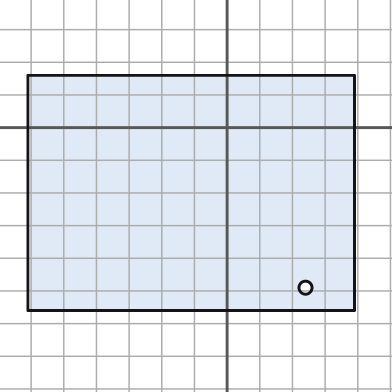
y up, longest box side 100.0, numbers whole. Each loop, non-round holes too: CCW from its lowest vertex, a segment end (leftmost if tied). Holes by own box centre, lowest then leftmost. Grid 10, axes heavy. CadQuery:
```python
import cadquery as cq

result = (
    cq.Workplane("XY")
    .moveTo(-61.0, -56.0)
    .lineTo(39.0, -56.0)
    .lineTo(39.0, 16.0)
    .lineTo(-61.0, 16.0)
    .close()
    .moveTo(24.0, -49.0)
    .circle(2.0)
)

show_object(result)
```